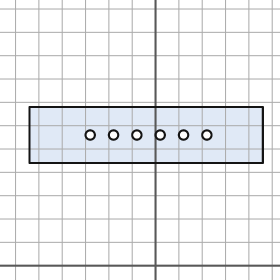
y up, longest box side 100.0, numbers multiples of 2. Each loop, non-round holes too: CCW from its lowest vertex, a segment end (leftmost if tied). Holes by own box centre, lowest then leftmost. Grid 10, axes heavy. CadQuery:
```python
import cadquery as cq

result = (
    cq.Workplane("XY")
    .moveTo(-54.0, 44.0)
    .lineTo(46.0, 44.0)
    .lineTo(46.0, 68.0)
    .lineTo(-54.0, 68.0)
    .close()
    .moveTo(-28.0, 56.0)
    .circle(2.0)
    .moveTo(-18.0, 56.0)
    .circle(2.0)
    .moveTo(-8.0, 56.0)
    .circle(2.0)
    .moveTo(2.0, 56.0)
    .circle(2.0)
    .moveTo(12.0, 56.0)
    .circle(2.0)
    .moveTo(22.0, 56.0)
    .circle(2.0)
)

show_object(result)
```